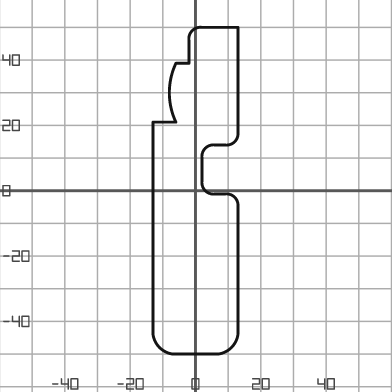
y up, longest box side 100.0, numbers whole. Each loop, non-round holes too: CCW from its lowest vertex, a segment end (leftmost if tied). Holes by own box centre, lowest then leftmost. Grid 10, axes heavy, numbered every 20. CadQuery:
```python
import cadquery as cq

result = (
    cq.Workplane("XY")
    .moveTo(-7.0, -50.0)
    .lineTo(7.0, -50.0)
    .threePointArc((11.0, -48.0), (13.0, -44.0))
    .lineTo(13.0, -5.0)
    .threePointArc((12.0, -2.0), (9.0, -1.0))
    .lineTo(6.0, -1.0)
    .threePointArc((3.0, 0.0), (2.0, 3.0))
    .lineTo(2.0, 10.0)
    .threePointArc((3.0, 13.0), (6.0, 14.0))
    .lineTo(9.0, 14.0)
    .threePointArc((12.0, 15.0), (13.0, 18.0))
    .lineTo(13.0, 50.0)
    .lineTo(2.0, 50.0)
    .threePointArc((-1.0, 49.0), (-2.0, 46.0))
    .lineTo(-2.0, 39.0)
    .lineTo(-6.0, 39.0)
    .threePointArc((-8.0, 30.0), (-6.0, 21.0))
    .lineTo(-13.0, 21.0)
    .lineTo(-13.0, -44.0)
    .threePointArc((-11.0, -48.0), (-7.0, -50.0))
    .close()
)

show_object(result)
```